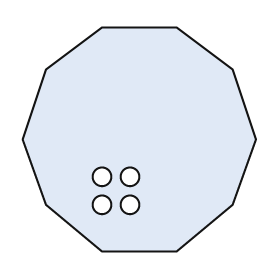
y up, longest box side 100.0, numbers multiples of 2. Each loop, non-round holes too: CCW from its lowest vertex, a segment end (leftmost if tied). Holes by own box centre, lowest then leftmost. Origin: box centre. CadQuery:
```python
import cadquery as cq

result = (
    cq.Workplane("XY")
    .moveTo(-16.0, -48.0)
    .lineTo(16.0, -48.0)
    .lineTo(40.0, -28.0)
    .lineTo(50.0, 0.0)
    .lineTo(40.0, 30.0)
    .lineTo(16.0, 48.0)
    .lineTo(-16.0, 48.0)
    .lineTo(-40.0, 30.0)
    .lineTo(-50.0, 0.0)
    .lineTo(-40.0, -28.0)
    .close()
    .moveTo(-16.0, -28.0)
    .circle(4.0)
    .moveTo(-4.0, -28.0)
    .circle(4.0)
    .moveTo(-16.0, -16.0)
    .circle(4.0)
    .moveTo(-4.0, -16.0)
    .circle(4.0)
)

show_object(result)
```